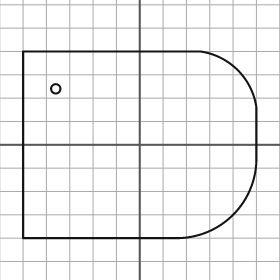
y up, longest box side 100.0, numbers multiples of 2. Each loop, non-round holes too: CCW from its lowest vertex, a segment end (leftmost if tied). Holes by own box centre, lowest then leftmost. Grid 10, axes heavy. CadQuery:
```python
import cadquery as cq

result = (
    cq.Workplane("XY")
    .moveTo(-50.0, -40.0)
    .lineTo(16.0, -40.0)
    .threePointArc((40.0, -30.0), (50.0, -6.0))
    .lineTo(50.0, 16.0)
    .threePointArc((42.0, 32.0), (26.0, 40.0))
    .lineTo(-50.0, 40.0)
    .close()
    .moveTo(-36.0, 24.0)
    .circle(2.0)
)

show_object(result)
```